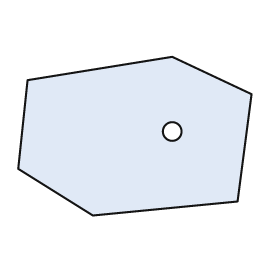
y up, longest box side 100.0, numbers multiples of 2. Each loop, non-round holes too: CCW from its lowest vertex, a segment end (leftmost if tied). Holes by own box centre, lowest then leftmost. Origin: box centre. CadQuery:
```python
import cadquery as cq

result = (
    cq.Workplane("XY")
    .moveTo(-18.0, -34.0)
    .lineTo(44.0, -28.0)
    .lineTo(50.0, 18.0)
    .lineTo(16.0, 34.0)
    .lineTo(-46.0, 24.0)
    .lineTo(-50.0, -14.0)
    .close()
    .moveTo(16.0, 2.0)
    .circle(4.0)
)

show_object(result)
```